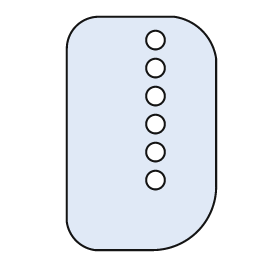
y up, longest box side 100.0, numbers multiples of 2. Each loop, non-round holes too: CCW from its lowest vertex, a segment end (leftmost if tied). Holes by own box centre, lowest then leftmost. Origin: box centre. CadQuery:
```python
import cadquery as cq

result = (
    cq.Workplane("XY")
    .moveTo(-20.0, -50.0)
    .lineTo(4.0, -50.0)
    .threePointArc((24.0, -42.0), (32.0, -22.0))
    .lineTo(32.0, 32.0)
    .threePointArc((26.0, 44.0), (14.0, 50.0))
    .lineTo(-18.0, 50.0)
    .threePointArc((-28.0, 46.0), (-32.0, 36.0))
    .lineTo(-32.0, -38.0)
    .threePointArc((-28.0, -46.0), (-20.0, -50.0))
    .close()
    .moveTo(6.0, -20.0)
    .circle(4.0)
    .moveTo(6.0, -8.0)
    .circle(4.0)
    .moveTo(6.0, 4.0)
    .circle(4.0)
    .moveTo(6.0, 16.0)
    .circle(4.0)
    .moveTo(6.0, 28.0)
    .circle(4.0)
    .moveTo(6.0, 40.0)
    .circle(4.0)
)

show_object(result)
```